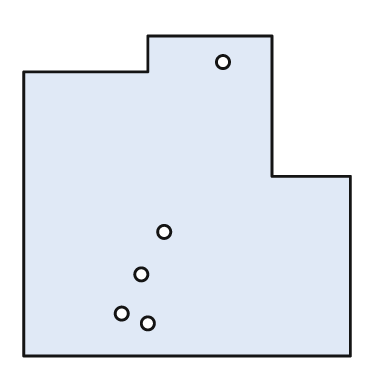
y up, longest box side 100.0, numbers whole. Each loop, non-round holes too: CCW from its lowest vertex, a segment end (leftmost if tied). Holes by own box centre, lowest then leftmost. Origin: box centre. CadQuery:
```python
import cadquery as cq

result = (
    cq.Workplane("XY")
    .moveTo(-50.0, -49.0)
    .lineTo(50.0, -49.0)
    .lineTo(50.0, 6.0)
    .lineTo(26.0, 6.0)
    .lineTo(26.0, 49.0)
    .lineTo(-12.0, 49.0)
    .lineTo(-12.0, 38.0)
    .lineTo(-50.0, 38.0)
    .close()
    .moveTo(-12.0, -39.0)
    .circle(2.0)
    .moveTo(-20.0, -36.0)
    .circle(2.0)
    .moveTo(-14.0, -24.0)
    .circle(2.0)
    .moveTo(-7.0, -11.0)
    .circle(2.0)
    .moveTo(11.0, 41.0)
    .circle(2.0)
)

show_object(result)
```